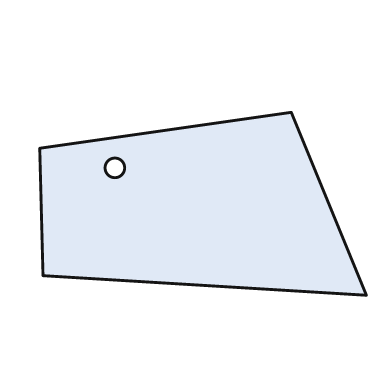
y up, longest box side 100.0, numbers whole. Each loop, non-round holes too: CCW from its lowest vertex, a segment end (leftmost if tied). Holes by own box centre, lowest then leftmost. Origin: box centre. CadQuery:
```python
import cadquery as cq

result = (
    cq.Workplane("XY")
    .moveTo(50.0, -28.0)
    .lineTo(27.0, 28.0)
    .lineTo(-50.0, 17.0)
    .lineTo(-49.0, -22.0)
    .close()
    .moveTo(-27.0, 11.0)
    .circle(3.0)
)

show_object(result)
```